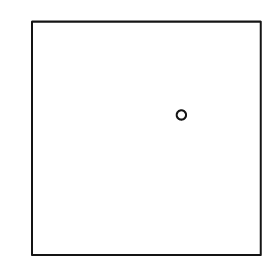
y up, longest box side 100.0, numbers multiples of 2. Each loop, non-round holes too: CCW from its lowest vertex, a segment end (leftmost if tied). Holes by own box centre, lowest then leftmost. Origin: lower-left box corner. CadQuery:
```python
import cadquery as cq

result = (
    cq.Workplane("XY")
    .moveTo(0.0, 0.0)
    .lineTo(98.0, 0.0)
    .lineTo(98.0, 100.0)
    .lineTo(0.0, 100.0)
    .close()
    .moveTo(64.0, 60.0)
    .circle(2.0)
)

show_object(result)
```